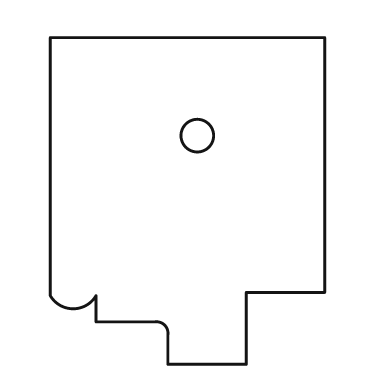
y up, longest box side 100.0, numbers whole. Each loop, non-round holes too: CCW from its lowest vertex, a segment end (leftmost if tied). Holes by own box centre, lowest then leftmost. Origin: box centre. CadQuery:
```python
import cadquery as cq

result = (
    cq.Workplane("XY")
    .moveTo(-6.0, -50.0)
    .lineTo(18.0, -50.0)
    .lineTo(18.0, -28.0)
    .lineTo(42.0, -28.0)
    .lineTo(42.0, 50.0)
    .lineTo(-42.0, 50.0)
    .lineTo(-42.0, -29.0)
    .threePointArc((-35.0, -33.0), (-28.0, -29.0))
    .lineTo(-28.0, -37.0)
    .lineTo(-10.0, -37.0)
    .threePointArc((-7.0, -38.0), (-6.0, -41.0))
    .close()
    .moveTo(3.0, 20.0)
    .circle(5.0)
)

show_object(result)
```